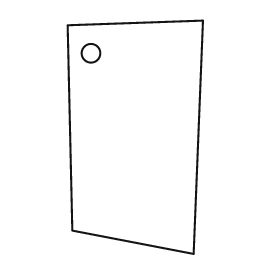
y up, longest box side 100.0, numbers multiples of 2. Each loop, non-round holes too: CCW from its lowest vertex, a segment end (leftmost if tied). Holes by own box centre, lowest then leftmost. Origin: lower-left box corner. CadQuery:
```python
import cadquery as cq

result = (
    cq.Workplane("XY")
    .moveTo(54.0, 0.0)
    .lineTo(58.0, 100.0)
    .lineTo(0.0, 98.0)
    .lineTo(2.0, 10.0)
    .close()
    .moveTo(10.0, 86.0)
    .circle(4.0)
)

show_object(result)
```